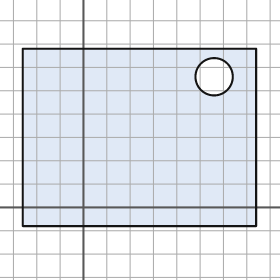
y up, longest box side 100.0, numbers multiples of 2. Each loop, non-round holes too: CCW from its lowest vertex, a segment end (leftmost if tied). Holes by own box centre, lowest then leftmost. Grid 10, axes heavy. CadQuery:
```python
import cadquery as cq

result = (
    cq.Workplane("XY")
    .moveTo(-26.0, -8.0)
    .lineTo(74.0, -8.0)
    .lineTo(74.0, 68.0)
    .lineTo(-26.0, 68.0)
    .close()
    .moveTo(56.0, 56.0)
    .circle(8.0)
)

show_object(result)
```